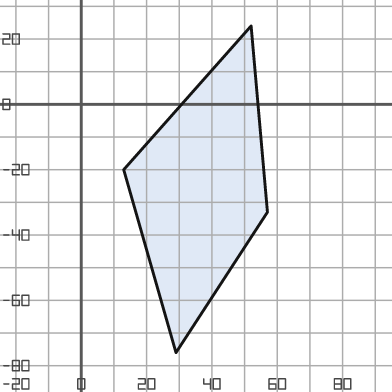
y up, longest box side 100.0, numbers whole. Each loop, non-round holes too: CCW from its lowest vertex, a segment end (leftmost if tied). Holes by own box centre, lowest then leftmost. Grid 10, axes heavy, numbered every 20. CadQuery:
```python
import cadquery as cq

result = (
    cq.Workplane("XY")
    .moveTo(29.0, -76.0)
    .lineTo(57.0, -33.0)
    .lineTo(52.0, 24.0)
    .lineTo(13.0, -20.0)
    .close()
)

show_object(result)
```